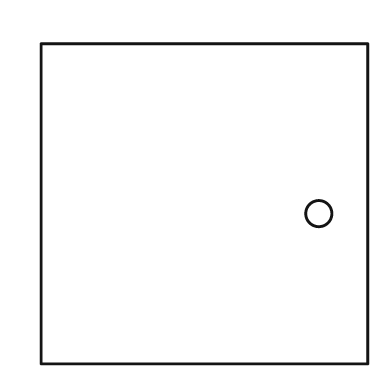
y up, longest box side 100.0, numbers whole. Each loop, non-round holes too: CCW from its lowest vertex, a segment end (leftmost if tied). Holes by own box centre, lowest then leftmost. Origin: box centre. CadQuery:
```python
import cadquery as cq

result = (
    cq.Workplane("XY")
    .moveTo(-50.0, -49.0)
    .lineTo(50.0, -49.0)
    .lineTo(50.0, 49.0)
    .lineTo(-50.0, 49.0)
    .close()
    .moveTo(35.0, -3.0)
    .circle(4.0)
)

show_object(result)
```